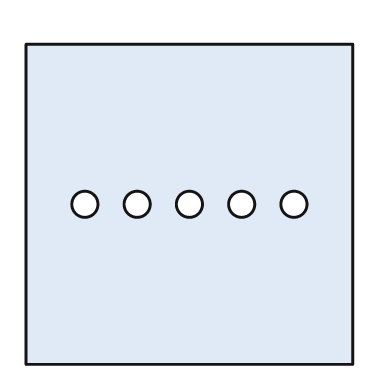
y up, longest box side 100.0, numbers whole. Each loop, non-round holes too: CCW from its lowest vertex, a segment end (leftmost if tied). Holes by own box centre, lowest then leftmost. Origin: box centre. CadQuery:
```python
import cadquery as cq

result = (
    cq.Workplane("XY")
    .moveTo(-50.0, -49.0)
    .lineTo(50.0, -49.0)
    .lineTo(50.0, 49.0)
    .lineTo(-50.0, 49.0)
    .close()
    .moveTo(-32.0, 0.0)
    .circle(4.0)
    .moveTo(-16.0, 0.0)
    .circle(4.0)
    .moveTo(0.0, 0.0)
    .circle(4.0)
    .moveTo(16.0, 0.0)
    .circle(4.0)
    .moveTo(32.0, 0.0)
    .circle(4.0)
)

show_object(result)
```